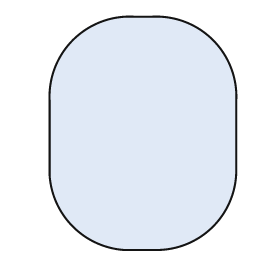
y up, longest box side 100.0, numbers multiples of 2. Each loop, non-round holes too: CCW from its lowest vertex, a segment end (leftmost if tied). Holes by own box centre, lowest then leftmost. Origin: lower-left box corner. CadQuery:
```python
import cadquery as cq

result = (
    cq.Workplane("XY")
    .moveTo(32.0, 0.0)
    .lineTo(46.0, 0.0)
    .threePointArc((70.0, 10.0), (80.0, 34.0))
    .lineTo(80.0, 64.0)
    .threePointArc((70.0, 90.0), (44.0, 100.0))
    .lineTo(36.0, 100.0)
    .threePointArc((10.0, 90.0), (0.0, 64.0))
    .lineTo(0.0, 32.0)
    .threePointArc((10.0, 10.0), (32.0, 0.0))
    .close()
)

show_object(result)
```